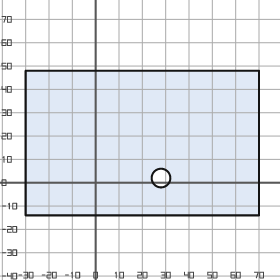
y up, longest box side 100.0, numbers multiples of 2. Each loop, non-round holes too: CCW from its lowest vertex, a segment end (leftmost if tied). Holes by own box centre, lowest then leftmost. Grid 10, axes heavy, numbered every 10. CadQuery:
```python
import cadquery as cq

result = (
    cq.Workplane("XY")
    .moveTo(-30.0, -14.0)
    .lineTo(70.0, -14.0)
    .lineTo(70.0, 48.0)
    .lineTo(-30.0, 48.0)
    .close()
    .moveTo(28.0, 2.0)
    .circle(4.0)
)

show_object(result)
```